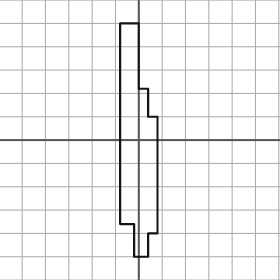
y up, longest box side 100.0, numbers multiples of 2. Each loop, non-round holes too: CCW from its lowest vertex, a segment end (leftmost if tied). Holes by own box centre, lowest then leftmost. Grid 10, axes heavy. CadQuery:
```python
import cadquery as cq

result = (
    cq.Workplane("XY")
    .moveTo(-2.0, -50.0)
    .lineTo(4.0, -50.0)
    .lineTo(4.0, -40.0)
    .lineTo(8.0, -40.0)
    .lineTo(8.0, 10.0)
    .lineTo(4.0, 10.0)
    .lineTo(4.0, 22.0)
    .lineTo(0.0, 22.0)
    .lineTo(0.0, 50.0)
    .lineTo(-8.0, 50.0)
    .lineTo(-8.0, -36.0)
    .lineTo(-2.0, -36.0)
    .close()
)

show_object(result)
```